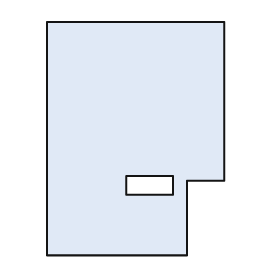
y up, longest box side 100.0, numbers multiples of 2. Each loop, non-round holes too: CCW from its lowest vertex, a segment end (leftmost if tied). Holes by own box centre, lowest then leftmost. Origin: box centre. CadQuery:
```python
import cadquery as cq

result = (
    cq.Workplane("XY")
    .moveTo(-38.0, -50.0)
    .lineTo(22.0, -50.0)
    .lineTo(22.0, -18.0)
    .lineTo(38.0, -18.0)
    .lineTo(38.0, 50.0)
    .lineTo(-38.0, 50.0)
    .close()
    .moveTo(-4.0, -24.0)
    .lineTo(16.0, -24.0)
    .lineTo(16.0, -16.0)
    .lineTo(-4.0, -16.0)
    .close()
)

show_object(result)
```